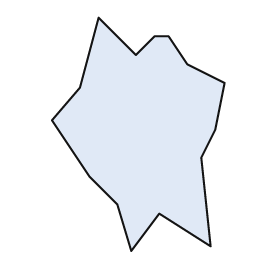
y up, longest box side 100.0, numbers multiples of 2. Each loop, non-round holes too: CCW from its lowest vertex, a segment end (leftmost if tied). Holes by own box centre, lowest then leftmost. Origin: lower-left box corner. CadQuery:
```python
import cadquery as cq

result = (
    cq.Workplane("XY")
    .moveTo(34.0, 0.0)
    .lineTo(46.0, 16.0)
    .lineTo(68.0, 2.0)
    .lineTo(64.0, 40.0)
    .lineTo(70.0, 52.0)
    .lineTo(74.0, 72.0)
    .lineTo(58.0, 80.0)
    .lineTo(50.0, 92.0)
    .lineTo(44.0, 92.0)
    .lineTo(36.0, 84.0)
    .lineTo(20.0, 100.0)
    .lineTo(12.0, 70.0)
    .lineTo(0.0, 56.0)
    .lineTo(16.0, 32.0)
    .lineTo(28.0, 20.0)
    .close()
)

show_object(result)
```